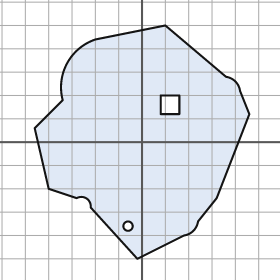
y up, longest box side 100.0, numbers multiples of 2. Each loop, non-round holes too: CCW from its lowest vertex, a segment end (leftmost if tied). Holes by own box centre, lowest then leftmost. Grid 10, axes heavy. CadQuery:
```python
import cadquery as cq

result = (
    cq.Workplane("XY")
    .moveTo(-2.0, -50.0)
    .lineTo(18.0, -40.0)
    .threePointArc((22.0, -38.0), (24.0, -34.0))
    .lineTo(32.0, -24.0)
    .lineTo(46.0, 12.0)
    .lineTo(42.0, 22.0)
    .threePointArc((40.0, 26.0), (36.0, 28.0))
    .lineTo(10.0, 50.0)
    .lineTo(-20.0, 44.0)
    .threePointArc((-32.0, 34.0), (-34.0, 18.0))
    .lineTo(-46.0, 6.0)
    .lineTo(-40.0, -20.0)
    .lineTo(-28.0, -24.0)
    .threePointArc((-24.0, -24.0), (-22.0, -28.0))
    .close()
    .moveTo(-6.0, -36.0)
    .circle(2.0)
    .moveTo(8.0, 12.0)
    .lineTo(16.0, 12.0)
    .lineTo(16.0, 20.0)
    .lineTo(8.0, 20.0)
    .close()
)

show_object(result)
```